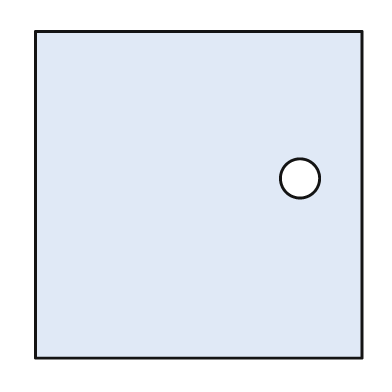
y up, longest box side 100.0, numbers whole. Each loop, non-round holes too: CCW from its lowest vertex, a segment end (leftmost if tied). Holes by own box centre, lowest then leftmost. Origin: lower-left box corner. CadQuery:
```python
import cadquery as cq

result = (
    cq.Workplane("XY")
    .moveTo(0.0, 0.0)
    .lineTo(100.0, 0.0)
    .lineTo(100.0, 100.0)
    .lineTo(0.0, 100.0)
    .close()
    .moveTo(81.0, 55.0)
    .circle(6.0)
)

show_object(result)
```